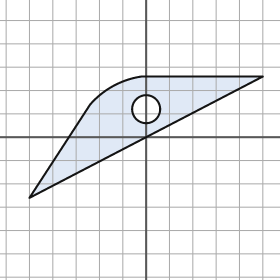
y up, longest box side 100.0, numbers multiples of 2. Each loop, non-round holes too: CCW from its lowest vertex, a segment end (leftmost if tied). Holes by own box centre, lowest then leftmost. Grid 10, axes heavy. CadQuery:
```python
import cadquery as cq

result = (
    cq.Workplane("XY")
    .moveTo(-50.0, -26.0)
    .lineTo(50.0, 26.0)
    .lineTo(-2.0, 26.0)
    .threePointArc((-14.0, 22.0), (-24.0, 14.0))
    .close()
    .moveTo(0.0, 12.0)
    .circle(6.0)
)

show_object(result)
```